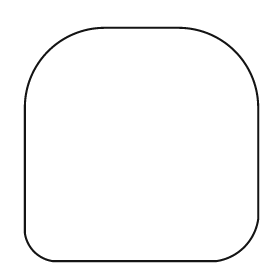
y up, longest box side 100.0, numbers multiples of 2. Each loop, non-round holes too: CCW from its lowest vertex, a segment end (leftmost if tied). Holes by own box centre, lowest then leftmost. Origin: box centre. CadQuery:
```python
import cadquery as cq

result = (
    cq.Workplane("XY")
    .moveTo(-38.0, -50.0)
    .lineTo(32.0, -50.0)
    .threePointArc((44.0, -44.0), (50.0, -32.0))
    .lineTo(50.0, 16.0)
    .threePointArc((40.0, 40.0), (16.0, 50.0))
    .lineTo(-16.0, 50.0)
    .threePointArc((-40.0, 40.0), (-50.0, 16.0))
    .lineTo(-50.0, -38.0)
    .threePointArc((-46.0, -46.0), (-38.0, -50.0))
    .close()
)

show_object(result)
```